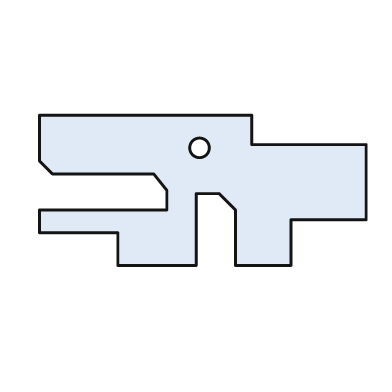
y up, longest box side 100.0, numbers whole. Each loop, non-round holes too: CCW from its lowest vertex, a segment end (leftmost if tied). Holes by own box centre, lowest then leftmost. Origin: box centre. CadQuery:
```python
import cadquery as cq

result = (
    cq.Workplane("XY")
    .moveTo(-26.0, -23.0)
    .lineTo(-2.0, -23.0)
    .lineTo(-2.0, -1.0)
    .lineTo(5.0, -1.0)
    .lineTo(10.0, -6.0)
    .lineTo(10.0, -23.0)
    .lineTo(27.0, -23.0)
    .lineTo(27.0, -9.0)
    .lineTo(50.0, -9.0)
    .lineTo(50.0, 14.0)
    .lineTo(15.0, 14.0)
    .lineTo(15.0, 23.0)
    .lineTo(-50.0, 23.0)
    .lineTo(-50.0, 9.0)
    .lineTo(-46.0, 5.0)
    .lineTo(-15.0, 5.0)
    .lineTo(-11.0, 0.0)
    .lineTo(-11.0, -6.0)
    .lineTo(-50.0, -6.0)
    .lineTo(-50.0, -13.0)
    .lineTo(-26.0, -13.0)
    .close()
    .moveTo(-1.0, 13.0)
    .circle(3.0)
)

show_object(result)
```